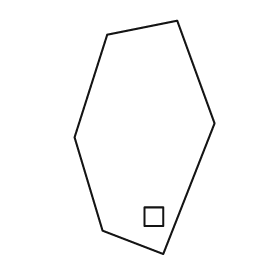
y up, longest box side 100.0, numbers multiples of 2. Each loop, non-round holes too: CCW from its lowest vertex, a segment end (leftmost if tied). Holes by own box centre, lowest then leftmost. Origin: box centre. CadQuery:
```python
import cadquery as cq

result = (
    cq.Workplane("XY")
    .moveTo(8.0, -50.0)
    .lineTo(30.0, 6.0)
    .lineTo(14.0, 50.0)
    .lineTo(-16.0, 44.0)
    .lineTo(-30.0, 0.0)
    .lineTo(-18.0, -40.0)
    .close()
    .moveTo(0.0, -38.0)
    .lineTo(8.0, -38.0)
    .lineTo(8.0, -30.0)
    .lineTo(0.0, -30.0)
    .close()
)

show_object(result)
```